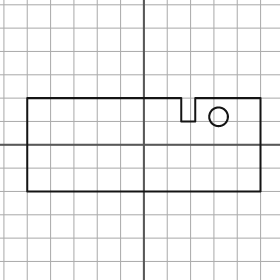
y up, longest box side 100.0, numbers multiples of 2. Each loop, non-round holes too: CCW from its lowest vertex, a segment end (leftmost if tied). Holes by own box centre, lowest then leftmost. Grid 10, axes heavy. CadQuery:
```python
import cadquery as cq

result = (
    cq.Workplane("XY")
    .moveTo(-50.0, -20.0)
    .lineTo(50.0, -20.0)
    .lineTo(50.0, 20.0)
    .lineTo(22.0, 20.0)
    .lineTo(22.0, 10.0)
    .lineTo(16.0, 10.0)
    .lineTo(16.0, 20.0)
    .lineTo(-50.0, 20.0)
    .close()
    .moveTo(32.0, 12.0)
    .circle(4.0)
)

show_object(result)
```